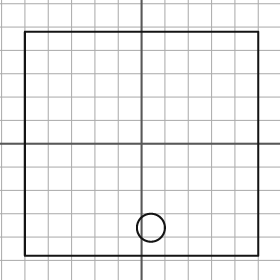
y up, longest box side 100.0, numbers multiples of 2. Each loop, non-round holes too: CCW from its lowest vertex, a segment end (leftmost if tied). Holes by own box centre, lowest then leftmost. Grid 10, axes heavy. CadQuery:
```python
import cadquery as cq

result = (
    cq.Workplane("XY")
    .moveTo(-50.0, -48.0)
    .lineTo(50.0, -48.0)
    .lineTo(50.0, 48.0)
    .lineTo(-50.0, 48.0)
    .close()
    .moveTo(4.0, -36.0)
    .circle(6.0)
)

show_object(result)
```